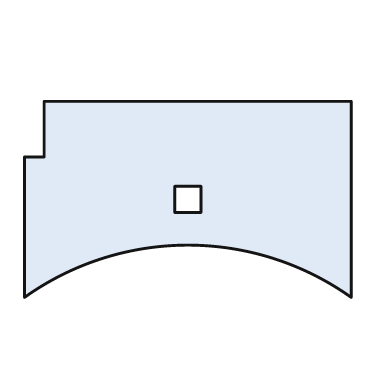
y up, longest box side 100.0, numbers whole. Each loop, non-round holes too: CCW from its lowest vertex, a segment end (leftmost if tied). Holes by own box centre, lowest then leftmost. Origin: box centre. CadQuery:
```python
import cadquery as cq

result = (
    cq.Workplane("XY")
    .moveTo(-50.0, -30.0)
    .threePointArc((0.0, -14.0), (50.0, -30.0))
    .lineTo(50.0, 30.0)
    .lineTo(-44.0, 30.0)
    .lineTo(-44.0, 13.0)
    .lineTo(-50.0, 13.0)
    .close()
    .moveTo(-4.0, -4.0)
    .lineTo(4.0, -4.0)
    .lineTo(4.0, 4.0)
    .lineTo(-4.0, 4.0)
    .close()
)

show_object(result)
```